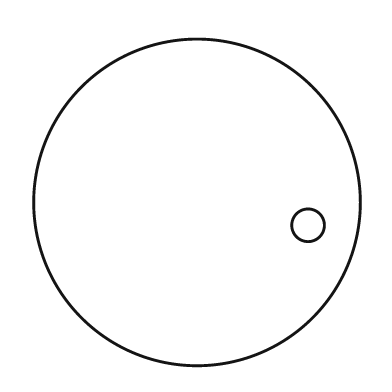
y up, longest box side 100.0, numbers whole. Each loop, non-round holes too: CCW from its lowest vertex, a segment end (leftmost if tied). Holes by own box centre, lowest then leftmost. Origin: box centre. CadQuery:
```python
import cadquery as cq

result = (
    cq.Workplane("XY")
    .moveTo(0.0, 0.0)
    .circle(50.0)
    .moveTo(34.0, -7.0)
    .circle(5.0)
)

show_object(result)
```